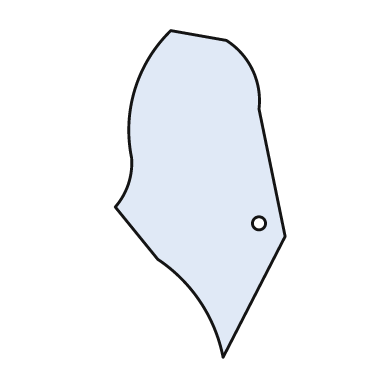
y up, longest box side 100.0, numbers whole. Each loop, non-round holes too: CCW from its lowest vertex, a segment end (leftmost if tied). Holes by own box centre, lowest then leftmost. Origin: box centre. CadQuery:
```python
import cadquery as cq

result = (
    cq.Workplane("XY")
    .moveTo(7.0, -50.0)
    .lineTo(26.0, -13.0)
    .lineTo(18.0, 26.0)
    .threePointArc((16.0, 38.0), (8.0, 47.0))
    .lineTo(-9.0, 50.0)
    .threePointArc((-20.0, 32.0), (-21.0, 11.0))
    .threePointArc((-22.0, 3.0), (-26.0, -4.0))
    .lineTo(-13.0, -20.0)
    .threePointArc((0.0, -33.0), (7.0, -50.0))
    .close()
    .moveTo(18.0, -9.0)
    .circle(2.0)
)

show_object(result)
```